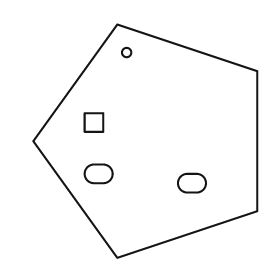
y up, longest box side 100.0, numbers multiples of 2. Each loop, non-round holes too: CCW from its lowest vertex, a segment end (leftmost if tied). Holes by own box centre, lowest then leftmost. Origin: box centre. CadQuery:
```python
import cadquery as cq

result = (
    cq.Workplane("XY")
    .moveTo(-12.0, -50.0)
    .lineTo(48.0, -30.0)
    .lineTo(48.0, 30.0)
    .lineTo(-12.0, 50.0)
    .lineTo(-48.0, 0.0)
    .close()
    .moveTo(18.0, -22.0)
    .lineTo(22.0, -22.0)
    .threePointArc((26.0, -18.0), (22.0, -14.0))
    .lineTo(18.0, -14.0)
    .threePointArc((14.0, -18.0), (18.0, -22.0))
    .close()
    .moveTo(-22.0, -18.0)
    .lineTo(-18.0, -18.0)
    .threePointArc((-14.0, -14.0), (-18.0, -10.0))
    .lineTo(-22.0, -10.0)
    .threePointArc((-26.0, -14.0), (-22.0, -18.0))
    .close()
    .moveTo(-26.0, 4.0)
    .lineTo(-18.0, 4.0)
    .lineTo(-18.0, 12.0)
    .lineTo(-26.0, 12.0)
    .close()
    .moveTo(-8.0, 38.0)
    .circle(2.0)
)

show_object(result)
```